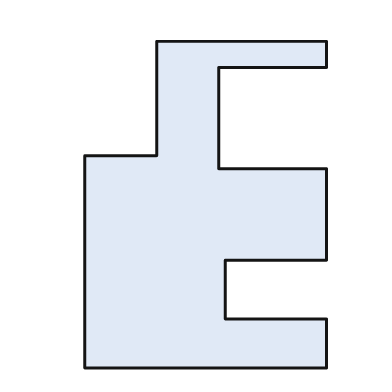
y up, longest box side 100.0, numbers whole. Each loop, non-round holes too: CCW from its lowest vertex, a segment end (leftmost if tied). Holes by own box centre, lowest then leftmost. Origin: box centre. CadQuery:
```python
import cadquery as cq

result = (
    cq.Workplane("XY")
    .moveTo(-37.0, -50.0)
    .lineTo(37.0, -50.0)
    .lineTo(37.0, -35.0)
    .lineTo(6.0, -35.0)
    .lineTo(6.0, -17.0)
    .lineTo(37.0, -17.0)
    .lineTo(37.0, 11.0)
    .lineTo(4.0, 11.0)
    .lineTo(4.0, 42.0)
    .lineTo(37.0, 42.0)
    .lineTo(37.0, 50.0)
    .lineTo(-15.0, 50.0)
    .lineTo(-15.0, 15.0)
    .lineTo(-37.0, 15.0)
    .close()
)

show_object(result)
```